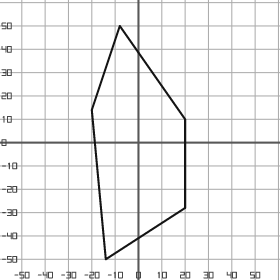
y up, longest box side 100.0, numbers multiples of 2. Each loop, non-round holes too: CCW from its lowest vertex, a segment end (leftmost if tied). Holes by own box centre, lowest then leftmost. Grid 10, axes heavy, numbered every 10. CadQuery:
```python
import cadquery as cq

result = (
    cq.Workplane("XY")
    .moveTo(-14.0, -50.0)
    .lineTo(20.0, -28.0)
    .lineTo(20.0, 10.0)
    .lineTo(-8.0, 50.0)
    .lineTo(-20.0, 14.0)
    .close()
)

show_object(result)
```